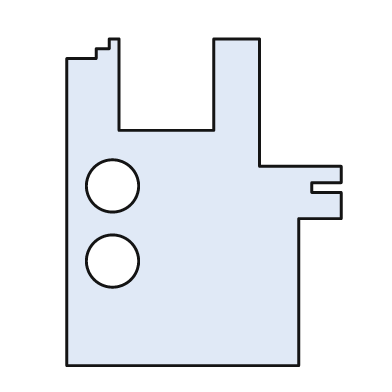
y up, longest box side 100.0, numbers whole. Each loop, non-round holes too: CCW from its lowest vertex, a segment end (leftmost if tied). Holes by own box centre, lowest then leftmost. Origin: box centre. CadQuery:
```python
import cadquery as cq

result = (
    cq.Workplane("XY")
    .moveTo(-42.0, -50.0)
    .lineTo(29.0, -50.0)
    .lineTo(29.0, -5.0)
    .lineTo(42.0, -5.0)
    .lineTo(42.0, 3.0)
    .lineTo(33.0, 3.0)
    .lineTo(33.0, 6.0)
    .lineTo(42.0, 6.0)
    .lineTo(42.0, 11.0)
    .lineTo(17.0, 11.0)
    .lineTo(17.0, 50.0)
    .lineTo(3.0, 50.0)
    .lineTo(3.0, 22.0)
    .lineTo(-26.0, 22.0)
    .lineTo(-26.0, 50.0)
    .lineTo(-29.0, 50.0)
    .lineTo(-29.0, 47.0)
    .lineTo(-33.0, 47.0)
    .lineTo(-33.0, 44.0)
    .lineTo(-42.0, 44.0)
    .close()
    .moveTo(-28.0, -18.0)
    .circle(8.0)
    .moveTo(-28.0, 5.0)
    .circle(8.0)
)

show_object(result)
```